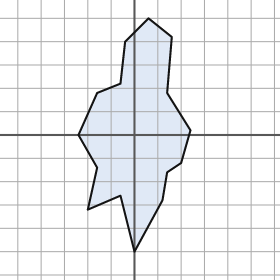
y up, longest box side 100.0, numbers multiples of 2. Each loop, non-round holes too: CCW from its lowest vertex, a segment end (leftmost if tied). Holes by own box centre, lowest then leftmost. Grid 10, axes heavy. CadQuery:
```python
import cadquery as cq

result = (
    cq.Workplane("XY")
    .moveTo(0.0, -50.0)
    .lineTo(12.0, -28.0)
    .lineTo(14.0, -16.0)
    .lineTo(20.0, -12.0)
    .lineTo(24.0, 2.0)
    .lineTo(14.0, 18.0)
    .lineTo(16.0, 42.0)
    .lineTo(6.0, 50.0)
    .lineTo(-4.0, 40.0)
    .lineTo(-6.0, 22.0)
    .lineTo(-16.0, 18.0)
    .lineTo(-24.0, 0.0)
    .lineTo(-16.0, -14.0)
    .lineTo(-20.0, -32.0)
    .lineTo(-6.0, -26.0)
    .close()
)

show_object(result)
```